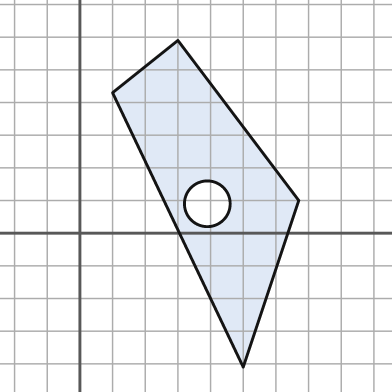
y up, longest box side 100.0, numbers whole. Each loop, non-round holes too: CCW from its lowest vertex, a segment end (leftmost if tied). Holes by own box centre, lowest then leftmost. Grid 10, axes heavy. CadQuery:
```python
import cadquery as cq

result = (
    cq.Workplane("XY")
    .moveTo(50.0, -41.0)
    .lineTo(67.0, 10.0)
    .lineTo(30.0, 59.0)
    .lineTo(10.0, 43.0)
    .close()
    .moveTo(39.0, 9.0)
    .circle(7.0)
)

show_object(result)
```